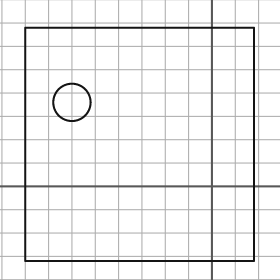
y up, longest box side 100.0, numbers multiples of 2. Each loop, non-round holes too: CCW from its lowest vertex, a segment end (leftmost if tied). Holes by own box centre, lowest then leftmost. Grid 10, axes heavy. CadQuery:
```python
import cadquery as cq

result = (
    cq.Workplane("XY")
    .moveTo(-80.0, -32.0)
    .lineTo(18.0, -32.0)
    .lineTo(18.0, 68.0)
    .lineTo(-80.0, 68.0)
    .close()
    .moveTo(-60.0, 36.0)
    .circle(8.0)
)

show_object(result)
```